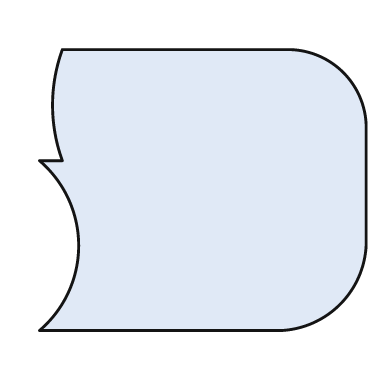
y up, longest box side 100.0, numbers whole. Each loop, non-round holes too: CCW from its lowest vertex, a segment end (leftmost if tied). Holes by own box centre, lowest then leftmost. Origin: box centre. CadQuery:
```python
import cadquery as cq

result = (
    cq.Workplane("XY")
    .moveTo(-50.0, -43.0)
    .lineTo(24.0, -43.0)
    .threePointArc((42.0, -35.0), (50.0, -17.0))
    .lineTo(50.0, 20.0)
    .threePointArc((43.0, 36.0), (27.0, 43.0))
    .lineTo(-43.0, 43.0)
    .threePointArc((-46.0, 26.0), (-43.0, 9.0))
    .lineTo(-50.0, 9.0)
    .threePointArc((-38.0, -17.0), (-50.0, -43.0))
    .close()
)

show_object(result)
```